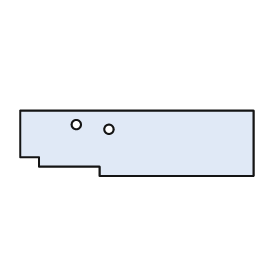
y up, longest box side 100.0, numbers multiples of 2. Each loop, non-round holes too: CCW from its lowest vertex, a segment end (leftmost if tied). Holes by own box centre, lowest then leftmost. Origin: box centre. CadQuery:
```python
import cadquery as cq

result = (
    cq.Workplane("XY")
    .moveTo(-16.0, -14.0)
    .lineTo(50.0, -14.0)
    .lineTo(50.0, 14.0)
    .lineTo(-50.0, 14.0)
    .lineTo(-50.0, -6.0)
    .lineTo(-42.0, -6.0)
    .lineTo(-42.0, -10.0)
    .lineTo(-16.0, -10.0)
    .close()
    .moveTo(-12.0, 6.0)
    .circle(2.0)
    .moveTo(-26.0, 8.0)
    .circle(2.0)
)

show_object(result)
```